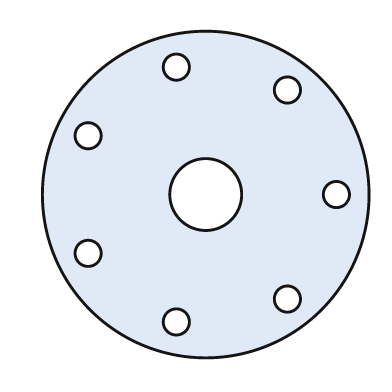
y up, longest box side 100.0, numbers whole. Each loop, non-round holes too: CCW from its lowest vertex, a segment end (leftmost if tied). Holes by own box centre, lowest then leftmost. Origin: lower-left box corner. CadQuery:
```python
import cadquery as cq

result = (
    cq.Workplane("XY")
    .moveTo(50.0, 50.0)
    .circle(50.0)
    .moveTo(41.0, 11.0)
    .circle(4.0)
    .moveTo(75.0, 18.0)
    .circle(4.0)
    .moveTo(14.0, 32.0)
    .circle(4.0)
    .moveTo(50.0, 50.0)
    .circle(11.0)
    .moveTo(90.0, 50.0)
    .circle(4.0)
    .moveTo(14.0, 68.0)
    .circle(4.0)
    .moveTo(75.0, 82.0)
    .circle(4.0)
    .moveTo(41.0, 89.0)
    .circle(4.0)
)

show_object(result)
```